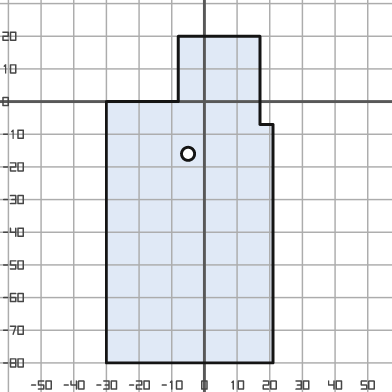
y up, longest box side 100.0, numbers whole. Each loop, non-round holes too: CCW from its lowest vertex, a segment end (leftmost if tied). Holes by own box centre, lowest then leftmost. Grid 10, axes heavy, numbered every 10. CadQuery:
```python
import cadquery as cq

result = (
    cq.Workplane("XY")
    .moveTo(-30.0, -80.0)
    .lineTo(21.0, -80.0)
    .lineTo(21.0, -7.0)
    .lineTo(17.0, -7.0)
    .lineTo(17.0, 20.0)
    .lineTo(-8.0, 20.0)
    .lineTo(-8.0, 0.0)
    .lineTo(-30.0, 0.0)
    .close()
    .moveTo(-5.0, -16.0)
    .circle(2.0)
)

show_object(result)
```